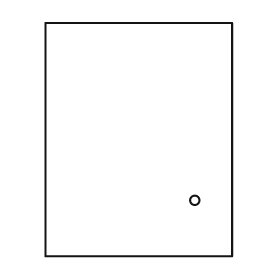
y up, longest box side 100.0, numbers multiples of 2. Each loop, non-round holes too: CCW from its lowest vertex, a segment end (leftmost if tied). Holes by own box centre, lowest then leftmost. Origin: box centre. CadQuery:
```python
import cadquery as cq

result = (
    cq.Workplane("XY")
    .moveTo(-40.0, -50.0)
    .lineTo(40.0, -50.0)
    .lineTo(40.0, 50.0)
    .lineTo(-40.0, 50.0)
    .close()
    .moveTo(24.0, -26.0)
    .circle(2.0)
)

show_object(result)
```